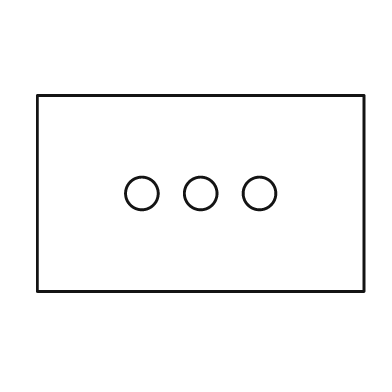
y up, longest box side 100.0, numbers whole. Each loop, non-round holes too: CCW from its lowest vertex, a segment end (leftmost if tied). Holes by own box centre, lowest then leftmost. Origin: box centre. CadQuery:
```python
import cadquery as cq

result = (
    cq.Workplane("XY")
    .moveTo(-50.0, -30.0)
    .lineTo(50.0, -30.0)
    .lineTo(50.0, 30.0)
    .lineTo(-50.0, 30.0)
    .close()
    .moveTo(-18.0, 0.0)
    .circle(5.0)
    .moveTo(0.0, 0.0)
    .circle(5.0)
    .moveTo(18.0, 0.0)
    .circle(5.0)
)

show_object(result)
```